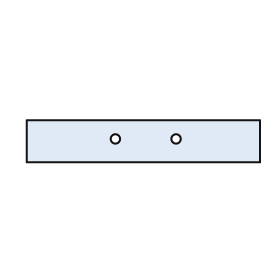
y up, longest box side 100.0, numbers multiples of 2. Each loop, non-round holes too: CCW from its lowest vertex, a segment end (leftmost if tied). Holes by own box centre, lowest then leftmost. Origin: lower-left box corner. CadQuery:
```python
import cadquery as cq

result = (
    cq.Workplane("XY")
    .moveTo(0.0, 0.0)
    .lineTo(100.0, 0.0)
    .lineTo(100.0, 18.0)
    .lineTo(0.0, 18.0)
    .close()
    .moveTo(38.0, 10.0)
    .circle(2.0)
    .moveTo(64.0, 10.0)
    .circle(2.0)
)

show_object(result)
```